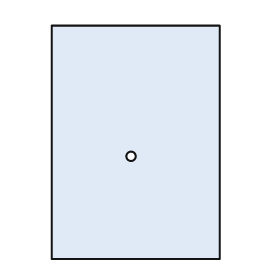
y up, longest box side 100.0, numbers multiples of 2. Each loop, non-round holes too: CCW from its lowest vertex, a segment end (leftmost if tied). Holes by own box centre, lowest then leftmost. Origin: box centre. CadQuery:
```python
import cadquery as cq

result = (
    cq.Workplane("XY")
    .moveTo(-36.0, -50.0)
    .lineTo(36.0, -50.0)
    .lineTo(36.0, 50.0)
    .lineTo(-36.0, 50.0)
    .close()
    .moveTo(-2.0, -6.0)
    .circle(2.0)
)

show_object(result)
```